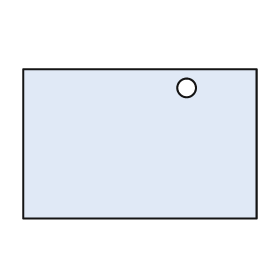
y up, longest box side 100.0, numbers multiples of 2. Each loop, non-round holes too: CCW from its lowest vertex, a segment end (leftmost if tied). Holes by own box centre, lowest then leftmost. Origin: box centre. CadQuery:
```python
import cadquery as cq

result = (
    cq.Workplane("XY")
    .moveTo(-50.0, -32.0)
    .lineTo(50.0, -32.0)
    .lineTo(50.0, 32.0)
    .lineTo(-50.0, 32.0)
    .close()
    .moveTo(20.0, 24.0)
    .circle(4.0)
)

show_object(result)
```